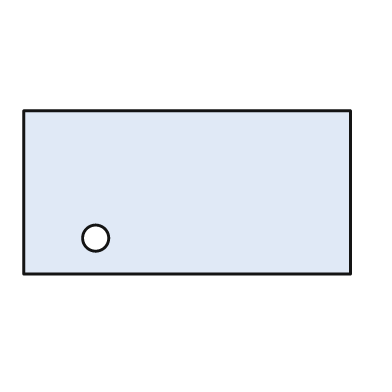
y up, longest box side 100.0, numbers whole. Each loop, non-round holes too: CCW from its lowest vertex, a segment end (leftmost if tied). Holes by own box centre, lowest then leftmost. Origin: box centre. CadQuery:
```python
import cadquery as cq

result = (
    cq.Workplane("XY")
    .moveTo(-50.0, -25.0)
    .lineTo(50.0, -25.0)
    .lineTo(50.0, 25.0)
    .lineTo(-50.0, 25.0)
    .close()
    .moveTo(-28.0, -14.0)
    .circle(4.0)
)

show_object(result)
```